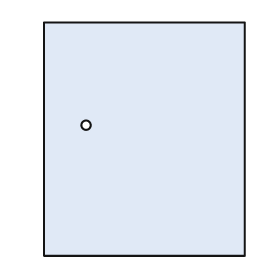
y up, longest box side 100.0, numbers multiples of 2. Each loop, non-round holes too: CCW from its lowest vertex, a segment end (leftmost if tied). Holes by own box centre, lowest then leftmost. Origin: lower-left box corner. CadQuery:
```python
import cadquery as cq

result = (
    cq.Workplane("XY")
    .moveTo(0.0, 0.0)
    .lineTo(86.0, 0.0)
    .lineTo(86.0, 100.0)
    .lineTo(0.0, 100.0)
    .close()
    .moveTo(18.0, 56.0)
    .circle(2.0)
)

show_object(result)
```